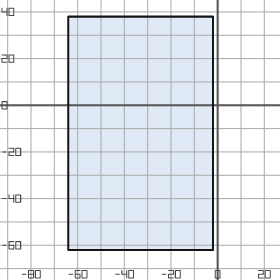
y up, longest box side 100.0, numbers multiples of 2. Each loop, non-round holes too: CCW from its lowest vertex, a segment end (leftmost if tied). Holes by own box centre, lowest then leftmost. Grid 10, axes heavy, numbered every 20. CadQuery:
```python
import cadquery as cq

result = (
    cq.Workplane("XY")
    .moveTo(-64.0, -62.0)
    .lineTo(-2.0, -62.0)
    .lineTo(-2.0, 38.0)
    .lineTo(-64.0, 38.0)
    .close()
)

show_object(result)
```